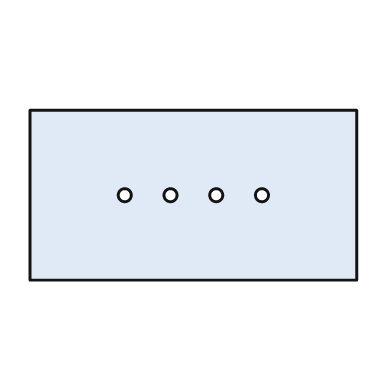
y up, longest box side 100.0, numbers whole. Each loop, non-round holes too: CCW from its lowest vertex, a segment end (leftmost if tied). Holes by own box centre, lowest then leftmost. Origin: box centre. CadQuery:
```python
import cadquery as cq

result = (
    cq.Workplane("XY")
    .moveTo(-50.0, -26.0)
    .lineTo(50.0, -26.0)
    .lineTo(50.0, 26.0)
    .lineTo(-50.0, 26.0)
    .close()
    .moveTo(-21.0, 0.0)
    .circle(2.0)
    .moveTo(-7.0, 0.0)
    .circle(2.0)
    .moveTo(7.0, 0.0)
    .circle(2.0)
    .moveTo(21.0, 0.0)
    .circle(2.0)
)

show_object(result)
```